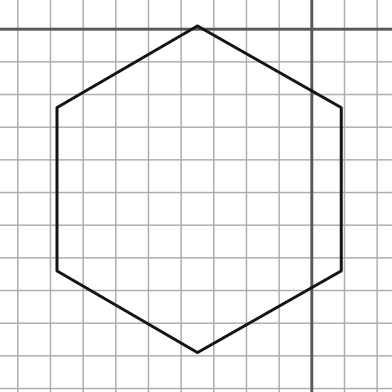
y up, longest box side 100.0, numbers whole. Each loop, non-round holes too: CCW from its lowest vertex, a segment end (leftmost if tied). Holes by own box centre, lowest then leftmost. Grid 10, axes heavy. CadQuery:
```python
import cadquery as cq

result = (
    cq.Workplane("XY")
    .moveTo(-35.0, -99.0)
    .lineTo(9.0, -74.0)
    .lineTo(9.0, -24.0)
    .lineTo(-35.0, 1.0)
    .lineTo(-78.0, -24.0)
    .lineTo(-78.0, -74.0)
    .close()
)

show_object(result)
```